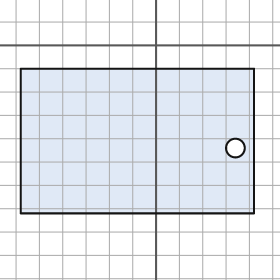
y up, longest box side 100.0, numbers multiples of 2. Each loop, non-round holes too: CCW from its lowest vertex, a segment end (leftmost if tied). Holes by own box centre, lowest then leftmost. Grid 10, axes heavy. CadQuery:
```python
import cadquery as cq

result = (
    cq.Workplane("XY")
    .moveTo(-58.0, -72.0)
    .lineTo(42.0, -72.0)
    .lineTo(42.0, -10.0)
    .lineTo(-58.0, -10.0)
    .close()
    .moveTo(34.0, -44.0)
    .circle(4.0)
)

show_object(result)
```